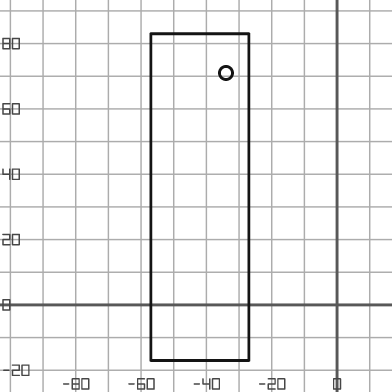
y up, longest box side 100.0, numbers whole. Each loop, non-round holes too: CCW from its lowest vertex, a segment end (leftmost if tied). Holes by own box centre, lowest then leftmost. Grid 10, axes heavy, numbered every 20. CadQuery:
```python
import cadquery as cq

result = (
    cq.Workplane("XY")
    .moveTo(-57.0, -17.0)
    .lineTo(-27.0, -17.0)
    .lineTo(-27.0, 83.0)
    .lineTo(-57.0, 83.0)
    .close()
    .moveTo(-34.0, 71.0)
    .circle(2.0)
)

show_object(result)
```